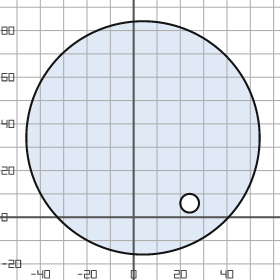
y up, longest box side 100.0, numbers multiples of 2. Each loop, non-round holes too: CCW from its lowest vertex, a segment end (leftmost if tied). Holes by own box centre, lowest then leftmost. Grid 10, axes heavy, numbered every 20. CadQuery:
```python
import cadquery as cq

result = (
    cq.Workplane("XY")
    .moveTo(4.0, 34.0)
    .circle(50.0)
    .moveTo(24.0, 6.0)
    .circle(4.0)
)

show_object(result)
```